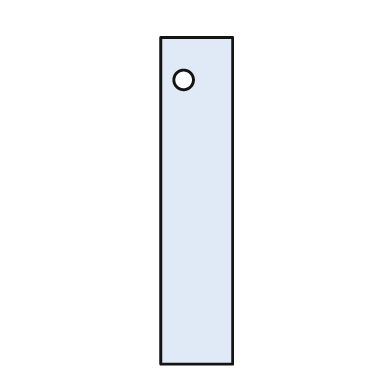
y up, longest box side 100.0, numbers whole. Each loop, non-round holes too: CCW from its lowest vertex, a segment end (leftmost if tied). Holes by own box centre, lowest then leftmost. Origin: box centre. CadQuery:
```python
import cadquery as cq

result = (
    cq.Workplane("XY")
    .moveTo(-11.0, -50.0)
    .lineTo(11.0, -50.0)
    .lineTo(11.0, 50.0)
    .lineTo(-11.0, 50.0)
    .close()
    .moveTo(-4.0, 37.0)
    .circle(3.0)
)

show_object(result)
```